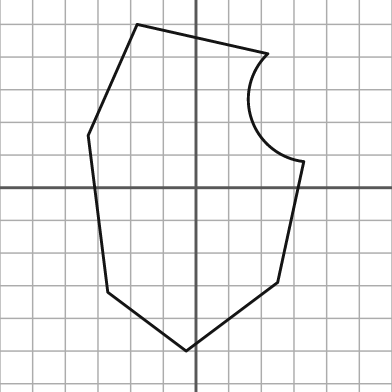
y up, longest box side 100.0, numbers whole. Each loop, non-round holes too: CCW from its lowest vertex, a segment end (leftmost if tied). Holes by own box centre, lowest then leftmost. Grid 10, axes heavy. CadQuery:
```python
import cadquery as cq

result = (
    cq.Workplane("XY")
    .moveTo(-3.0, -50.0)
    .lineTo(25.0, -29.0)
    .lineTo(33.0, 8.0)
    .threePointArc((17.0, 21.0), (22.0, 41.0))
    .lineTo(-18.0, 50.0)
    .lineTo(-33.0, 16.0)
    .lineTo(-27.0, -32.0)
    .close()
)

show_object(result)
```